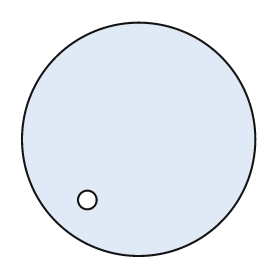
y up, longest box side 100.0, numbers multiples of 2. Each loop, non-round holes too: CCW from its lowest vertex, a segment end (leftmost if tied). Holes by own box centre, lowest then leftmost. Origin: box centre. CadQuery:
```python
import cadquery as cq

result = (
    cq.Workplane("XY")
    .moveTo(0.0, 0.0)
    .circle(50.0)
    .moveTo(-22.0, -26.0)
    .circle(4.0)
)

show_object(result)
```